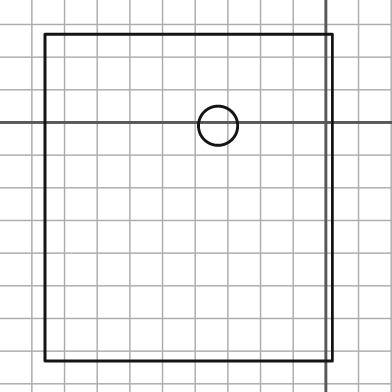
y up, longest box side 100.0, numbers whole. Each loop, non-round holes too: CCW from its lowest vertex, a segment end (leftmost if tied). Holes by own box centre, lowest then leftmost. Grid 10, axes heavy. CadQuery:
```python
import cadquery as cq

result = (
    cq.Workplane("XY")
    .moveTo(-86.0, -73.0)
    .lineTo(2.0, -73.0)
    .lineTo(2.0, 27.0)
    .lineTo(-86.0, 27.0)
    .close()
    .moveTo(-33.0, -1.0)
    .circle(6.0)
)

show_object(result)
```